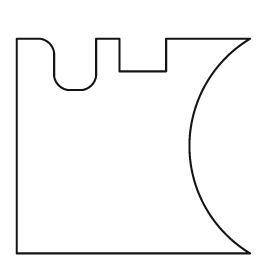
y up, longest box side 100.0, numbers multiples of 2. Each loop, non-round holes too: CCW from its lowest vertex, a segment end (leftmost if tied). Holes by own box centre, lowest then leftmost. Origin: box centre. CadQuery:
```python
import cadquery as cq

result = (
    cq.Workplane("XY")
    .moveTo(-50.0, -46.0)
    .lineTo(50.0, -46.0)
    .threePointArc((24.0, 0.0), (50.0, 46.0))
    .lineTo(14.0, 46.0)
    .lineTo(14.0, 32.0)
    .lineTo(-6.0, 32.0)
    .lineTo(-6.0, 46.0)
    .lineTo(-16.0, 46.0)
    .lineTo(-16.0, 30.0)
    .threePointArc((-18.0, 26.0), (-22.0, 24.0))
    .lineTo(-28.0, 24.0)
    .threePointArc((-32.0, 26.0), (-34.0, 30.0))
    .lineTo(-34.0, 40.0)
    .threePointArc((-36.0, 44.0), (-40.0, 46.0))
    .lineTo(-50.0, 46.0)
    .close()
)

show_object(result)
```